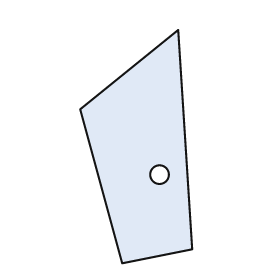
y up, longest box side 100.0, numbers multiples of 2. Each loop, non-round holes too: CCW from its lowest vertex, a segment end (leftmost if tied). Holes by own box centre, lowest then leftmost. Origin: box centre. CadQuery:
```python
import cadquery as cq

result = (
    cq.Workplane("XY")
    .moveTo(-6.0, -50.0)
    .lineTo(24.0, -44.0)
    .lineTo(18.0, 50.0)
    .lineTo(-24.0, 16.0)
    .close()
    .moveTo(10.0, -12.0)
    .circle(4.0)
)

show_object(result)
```